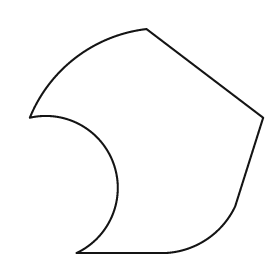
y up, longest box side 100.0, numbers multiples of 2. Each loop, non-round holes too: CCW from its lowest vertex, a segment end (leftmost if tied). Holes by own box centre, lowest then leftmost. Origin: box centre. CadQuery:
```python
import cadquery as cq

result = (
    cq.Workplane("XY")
    .moveTo(-30.0, -48.0)
    .lineTo(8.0, -48.0)
    .threePointArc((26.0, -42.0), (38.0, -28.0))
    .lineTo(50.0, 10.0)
    .lineTo(0.0, 48.0)
    .threePointArc((-30.0, 36.0), (-50.0, 10.0))
    .threePointArc((-14.0, -10.0), (-30.0, -48.0))
    .close()
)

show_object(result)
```